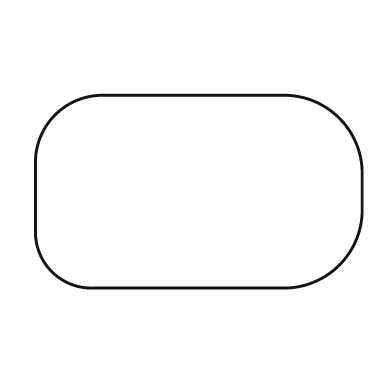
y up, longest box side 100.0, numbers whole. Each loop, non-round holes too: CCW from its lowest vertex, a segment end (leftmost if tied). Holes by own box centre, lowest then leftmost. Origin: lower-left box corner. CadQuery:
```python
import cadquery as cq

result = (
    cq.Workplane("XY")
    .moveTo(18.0, 0.0)
    .lineTo(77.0, 0.0)
    .threePointArc((93.0, 7.0), (100.0, 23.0))
    .lineTo(100.0, 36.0)
    .threePointArc((93.0, 52.0), (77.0, 59.0))
    .lineTo(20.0, 59.0)
    .threePointArc((6.0, 53.0), (0.0, 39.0))
    .lineTo(0.0, 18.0)
    .threePointArc((5.0, 5.0), (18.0, 0.0))
    .close()
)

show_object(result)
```